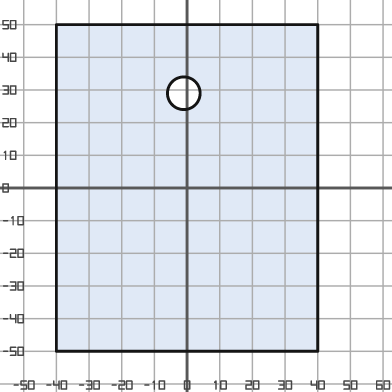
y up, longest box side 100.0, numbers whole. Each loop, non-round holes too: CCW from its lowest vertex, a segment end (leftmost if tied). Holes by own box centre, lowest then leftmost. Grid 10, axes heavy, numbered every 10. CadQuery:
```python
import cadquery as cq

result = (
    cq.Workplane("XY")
    .moveTo(-40.0, -50.0)
    .lineTo(40.0, -50.0)
    .lineTo(40.0, 50.0)
    .lineTo(-40.0, 50.0)
    .close()
    .moveTo(-1.0, 29.0)
    .circle(5.0)
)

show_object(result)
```